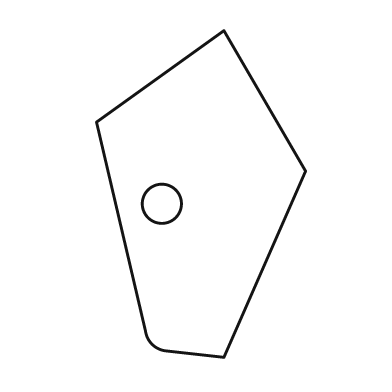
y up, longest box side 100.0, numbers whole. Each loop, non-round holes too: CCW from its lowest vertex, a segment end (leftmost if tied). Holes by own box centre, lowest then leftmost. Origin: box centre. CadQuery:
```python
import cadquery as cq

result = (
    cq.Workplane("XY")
    .moveTo(7.0, -50.0)
    .lineTo(32.0, 7.0)
    .lineTo(7.0, 50.0)
    .lineTo(-32.0, 22.0)
    .lineTo(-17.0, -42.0)
    .threePointArc((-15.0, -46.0), (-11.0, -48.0))
    .close()
    .moveTo(-12.0, -3.0)
    .circle(6.0)
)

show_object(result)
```